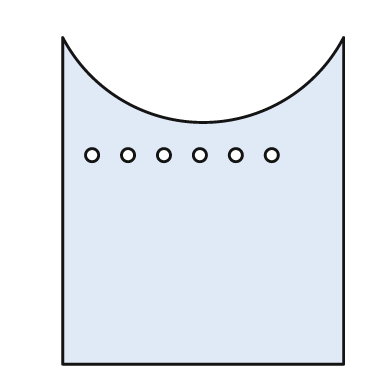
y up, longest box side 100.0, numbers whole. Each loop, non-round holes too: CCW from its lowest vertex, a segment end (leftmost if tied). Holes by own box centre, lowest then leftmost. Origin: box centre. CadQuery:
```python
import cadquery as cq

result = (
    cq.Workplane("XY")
    .moveTo(-43.0, -50.0)
    .lineTo(43.0, -50.0)
    .lineTo(43.0, 50.0)
    .threePointArc((0.0, 24.0), (-43.0, 50.0))
    .close()
    .moveTo(-34.0, 14.0)
    .circle(2.0)
    .moveTo(-23.0, 14.0)
    .circle(2.0)
    .moveTo(-12.0, 14.0)
    .circle(2.0)
    .moveTo(-1.0, 14.0)
    .circle(2.0)
    .moveTo(10.0, 14.0)
    .circle(2.0)
    .moveTo(21.0, 14.0)
    .circle(2.0)
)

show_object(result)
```